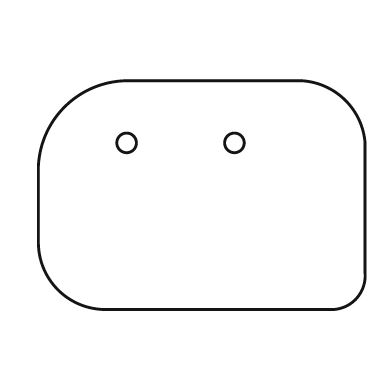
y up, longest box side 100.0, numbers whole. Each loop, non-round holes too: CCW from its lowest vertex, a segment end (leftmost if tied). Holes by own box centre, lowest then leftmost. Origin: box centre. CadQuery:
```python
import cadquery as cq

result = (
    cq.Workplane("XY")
    .moveTo(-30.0, -35.0)
    .lineTo(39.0, -35.0)
    .threePointArc((47.0, -32.0), (50.0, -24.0))
    .lineTo(50.0, 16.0)
    .threePointArc((44.0, 29.0), (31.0, 35.0))
    .lineTo(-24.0, 35.0)
    .threePointArc((-42.0, 27.0), (-50.0, 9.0))
    .lineTo(-50.0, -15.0)
    .threePointArc((-44.0, -29.0), (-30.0, -35.0))
    .close()
    .moveTo(-23.0, 16.0)
    .circle(3.0)
    .moveTo(10.0, 16.0)
    .circle(3.0)
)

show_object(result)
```